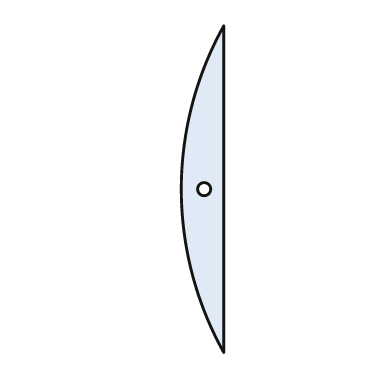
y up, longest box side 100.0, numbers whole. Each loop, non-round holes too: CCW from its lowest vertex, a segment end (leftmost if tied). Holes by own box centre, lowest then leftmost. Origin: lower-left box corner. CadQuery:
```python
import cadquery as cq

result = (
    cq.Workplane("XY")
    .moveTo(13.0, 0.0)
    .lineTo(13.0, 100.0)
    .threePointArc((0.0, 50.0), (13.0, 0.0))
    .close()
    .moveTo(7.0, 50.0)
    .circle(2.0)
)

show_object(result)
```